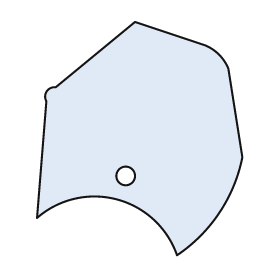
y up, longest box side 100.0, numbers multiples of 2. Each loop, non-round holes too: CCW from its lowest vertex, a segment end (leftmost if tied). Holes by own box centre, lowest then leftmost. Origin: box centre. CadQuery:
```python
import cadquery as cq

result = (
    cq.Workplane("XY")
    .moveTo(16.0, -50.0)
    .threePointArc((34.0, -32.0), (44.0, -8.0))
    .lineTo(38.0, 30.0)
    .threePointArc((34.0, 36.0), (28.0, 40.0))
    .lineTo(-2.0, 50.0)
    .lineTo(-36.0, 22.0)
    .threePointArc((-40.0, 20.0), (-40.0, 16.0))
    .lineTo(-44.0, -34.0)
    .threePointArc((-10.0, -26.0), (16.0, -50.0))
    .close()
    .moveTo(-6.0, -16.0)
    .circle(4.0)
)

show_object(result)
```